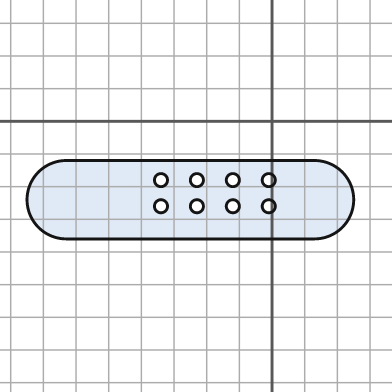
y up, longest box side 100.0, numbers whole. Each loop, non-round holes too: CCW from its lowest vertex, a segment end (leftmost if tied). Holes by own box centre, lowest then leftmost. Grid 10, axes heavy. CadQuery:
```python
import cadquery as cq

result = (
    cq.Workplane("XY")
    .moveTo(-63.0, -36.0)
    .lineTo(13.0, -36.0)
    .threePointArc((25.0, -24.0), (13.0, -12.0))
    .lineTo(-63.0, -12.0)
    .threePointArc((-75.0, -24.0), (-63.0, -36.0))
    .close()
    .moveTo(-34.0, -26.0)
    .circle(2.0)
    .moveTo(-23.0, -26.0)
    .circle(2.0)
    .moveTo(-12.0, -26.0)
    .circle(2.0)
    .moveTo(-1.0, -26.0)
    .circle(2.0)
    .moveTo(-34.0, -18.0)
    .circle(2.0)
    .moveTo(-23.0, -18.0)
    .circle(2.0)
    .moveTo(-12.0, -18.0)
    .circle(2.0)
    .moveTo(-1.0, -18.0)
    .circle(2.0)
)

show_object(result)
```